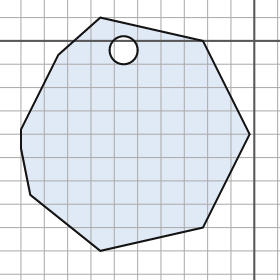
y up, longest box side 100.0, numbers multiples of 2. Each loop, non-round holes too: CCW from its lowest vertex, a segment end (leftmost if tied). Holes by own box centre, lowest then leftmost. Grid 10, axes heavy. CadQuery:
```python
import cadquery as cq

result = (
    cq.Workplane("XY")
    .moveTo(-66.0, -90.0)
    .lineTo(-22.0, -80.0)
    .lineTo(-2.0, -40.0)
    .lineTo(-22.0, 0.0)
    .lineTo(-66.0, 10.0)
    .lineTo(-84.0, -6.0)
    .lineTo(-100.0, -38.0)
    .lineTo(-100.0, -46.0)
    .lineTo(-96.0, -66.0)
    .close()
    .moveTo(-56.0, -4.0)
    .circle(6.0)
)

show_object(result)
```